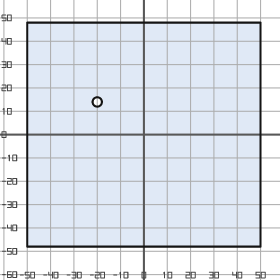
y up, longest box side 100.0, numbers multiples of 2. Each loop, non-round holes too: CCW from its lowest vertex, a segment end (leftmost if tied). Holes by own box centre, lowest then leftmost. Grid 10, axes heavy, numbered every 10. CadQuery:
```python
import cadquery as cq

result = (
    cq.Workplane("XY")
    .moveTo(-50.0, -48.0)
    .lineTo(50.0, -48.0)
    .lineTo(50.0, 48.0)
    .lineTo(-50.0, 48.0)
    .close()
    .moveTo(-20.0, 14.0)
    .circle(2.0)
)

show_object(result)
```